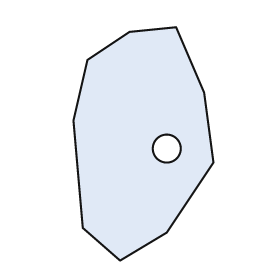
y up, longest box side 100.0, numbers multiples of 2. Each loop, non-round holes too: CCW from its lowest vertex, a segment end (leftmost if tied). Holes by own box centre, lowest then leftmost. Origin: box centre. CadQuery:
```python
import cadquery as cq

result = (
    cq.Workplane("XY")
    .moveTo(-10.0, -50.0)
    .lineTo(10.0, -38.0)
    .lineTo(30.0, -8.0)
    .lineTo(26.0, 22.0)
    .lineTo(14.0, 50.0)
    .lineTo(-6.0, 48.0)
    .lineTo(-24.0, 36.0)
    .lineTo(-30.0, 10.0)
    .lineTo(-26.0, -36.0)
    .close()
    .moveTo(10.0, -2.0)
    .circle(6.0)
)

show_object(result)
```